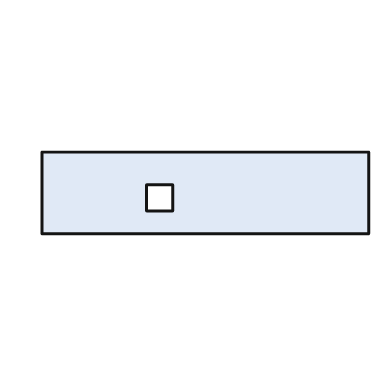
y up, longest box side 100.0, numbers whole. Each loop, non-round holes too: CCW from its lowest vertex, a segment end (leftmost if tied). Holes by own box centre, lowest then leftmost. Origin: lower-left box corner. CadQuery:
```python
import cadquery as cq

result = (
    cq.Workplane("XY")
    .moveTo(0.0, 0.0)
    .lineTo(100.0, 0.0)
    .lineTo(100.0, 25.0)
    .lineTo(0.0, 25.0)
    .close()
    .moveTo(32.0, 7.0)
    .lineTo(40.0, 7.0)
    .lineTo(40.0, 15.0)
    .lineTo(32.0, 15.0)
    .close()
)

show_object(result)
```